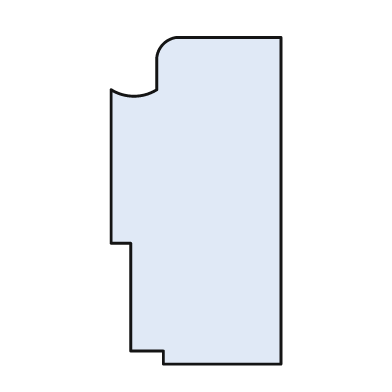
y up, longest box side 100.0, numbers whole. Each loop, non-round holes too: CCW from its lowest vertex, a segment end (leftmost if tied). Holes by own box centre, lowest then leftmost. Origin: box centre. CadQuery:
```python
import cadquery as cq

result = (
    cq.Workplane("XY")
    .moveTo(-10.0, -50.0)
    .lineTo(26.0, -50.0)
    .lineTo(26.0, 50.0)
    .lineTo(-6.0, 50.0)
    .threePointArc((-10.0, 48.0), (-12.0, 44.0))
    .lineTo(-12.0, 34.0)
    .threePointArc((-19.0, 32.0), (-26.0, 34.0))
    .lineTo(-26.0, -13.0)
    .lineTo(-20.0, -13.0)
    .lineTo(-20.0, -46.0)
    .lineTo(-10.0, -46.0)
    .close()
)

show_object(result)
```